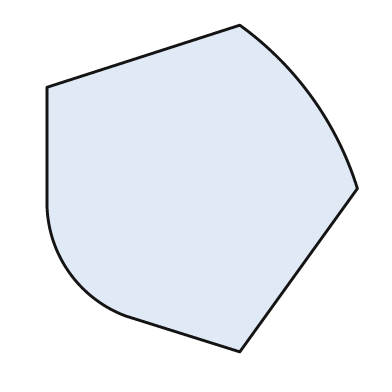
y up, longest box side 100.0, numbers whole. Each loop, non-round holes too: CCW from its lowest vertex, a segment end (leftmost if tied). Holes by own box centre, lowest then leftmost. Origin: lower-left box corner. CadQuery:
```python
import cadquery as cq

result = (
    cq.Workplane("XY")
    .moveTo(59.0, 0.0)
    .lineTo(95.0, 50.0)
    .threePointArc((81.0, 78.0), (59.0, 100.0))
    .lineTo(0.0, 81.0)
    .lineTo(0.0, 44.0)
    .threePointArc((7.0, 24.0), (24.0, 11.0))
    .close()
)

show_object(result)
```